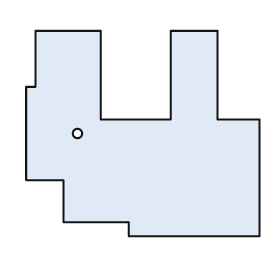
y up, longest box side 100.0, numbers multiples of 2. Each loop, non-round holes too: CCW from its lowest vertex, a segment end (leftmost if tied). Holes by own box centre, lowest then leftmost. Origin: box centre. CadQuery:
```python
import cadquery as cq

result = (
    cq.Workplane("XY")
    .moveTo(-6.0, -44.0)
    .lineTo(50.0, -44.0)
    .lineTo(50.0, 6.0)
    .lineTo(32.0, 6.0)
    .lineTo(32.0, 44.0)
    .lineTo(12.0, 44.0)
    .lineTo(12.0, 6.0)
    .lineTo(-18.0, 6.0)
    .lineTo(-18.0, 44.0)
    .lineTo(-46.0, 44.0)
    .lineTo(-46.0, 20.0)
    .lineTo(-50.0, 20.0)
    .lineTo(-50.0, -20.0)
    .lineTo(-34.0, -20.0)
    .lineTo(-34.0, -38.0)
    .lineTo(-6.0, -38.0)
    .close()
    .moveTo(-28.0, 0.0)
    .circle(2.0)
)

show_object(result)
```